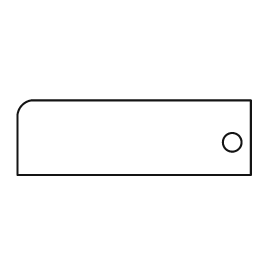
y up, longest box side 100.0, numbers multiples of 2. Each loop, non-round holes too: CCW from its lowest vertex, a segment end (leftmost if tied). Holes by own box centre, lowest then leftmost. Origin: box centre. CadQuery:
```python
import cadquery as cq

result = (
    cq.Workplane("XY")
    .moveTo(-50.0, -16.0)
    .lineTo(50.0, -16.0)
    .lineTo(50.0, 16.0)
    .lineTo(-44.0, 16.0)
    .threePointArc((-48.0, 14.0), (-50.0, 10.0))
    .close()
    .moveTo(42.0, -2.0)
    .circle(4.0)
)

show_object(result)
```